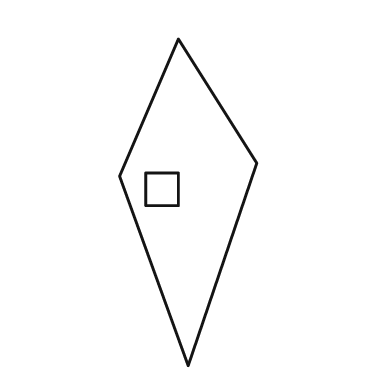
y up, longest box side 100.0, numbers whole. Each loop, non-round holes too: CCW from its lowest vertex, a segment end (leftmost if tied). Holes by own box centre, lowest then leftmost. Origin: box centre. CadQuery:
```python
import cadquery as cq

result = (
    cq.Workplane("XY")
    .moveTo(0.0, -50.0)
    .lineTo(21.0, 12.0)
    .lineTo(-3.0, 50.0)
    .lineTo(-21.0, 8.0)
    .close()
    .moveTo(-13.0, -1.0)
    .lineTo(-3.0, -1.0)
    .lineTo(-3.0, 9.0)
    .lineTo(-13.0, 9.0)
    .close()
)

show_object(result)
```